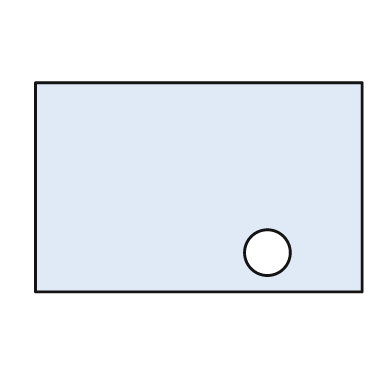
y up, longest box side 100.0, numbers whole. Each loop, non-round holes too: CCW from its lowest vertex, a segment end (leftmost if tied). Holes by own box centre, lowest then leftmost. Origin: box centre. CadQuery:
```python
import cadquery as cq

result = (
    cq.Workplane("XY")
    .moveTo(-50.0, -32.0)
    .lineTo(50.0, -32.0)
    .lineTo(50.0, 32.0)
    .lineTo(-50.0, 32.0)
    .close()
    .moveTo(21.0, -20.0)
    .circle(7.0)
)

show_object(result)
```